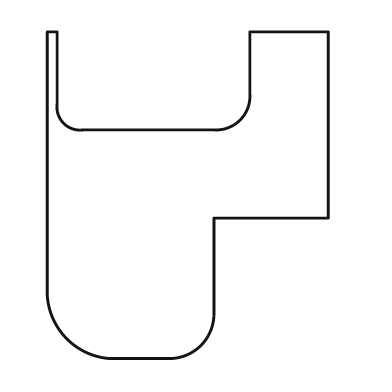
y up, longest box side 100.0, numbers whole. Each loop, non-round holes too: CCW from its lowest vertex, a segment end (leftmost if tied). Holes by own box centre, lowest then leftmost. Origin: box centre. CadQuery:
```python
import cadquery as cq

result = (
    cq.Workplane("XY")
    .moveTo(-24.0, -50.0)
    .lineTo(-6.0, -50.0)
    .threePointArc((4.0, -46.0), (8.0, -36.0))
    .lineTo(8.0, -7.0)
    .lineTo(43.0, -7.0)
    .lineTo(43.0, 50.0)
    .lineTo(19.0, 50.0)
    .lineTo(19.0, 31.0)
    .threePointArc((16.0, 23.0), (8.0, 20.0))
    .lineTo(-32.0, 20.0)
    .threePointArc((-38.0, 22.0), (-40.0, 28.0))
    .lineTo(-40.0, 50.0)
    .lineTo(-43.0, 50.0)
    .lineTo(-43.0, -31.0)
    .threePointArc((-37.0, -44.0), (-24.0, -50.0))
    .close()
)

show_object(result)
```